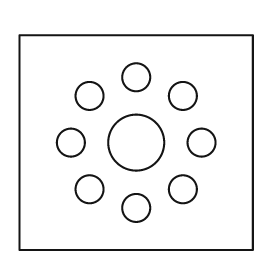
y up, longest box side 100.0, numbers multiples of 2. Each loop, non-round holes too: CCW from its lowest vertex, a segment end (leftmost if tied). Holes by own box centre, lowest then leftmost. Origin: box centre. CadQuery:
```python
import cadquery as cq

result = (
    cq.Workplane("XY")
    .moveTo(-50.0, -46.0)
    .lineTo(50.0, -46.0)
    .lineTo(50.0, 46.0)
    .lineTo(-50.0, 46.0)
    .close()
    .moveTo(0.0, -28.0)
    .circle(6.0)
    .moveTo(-20.0, -20.0)
    .circle(6.0)
    .moveTo(20.0, -20.0)
    .circle(6.0)
    .moveTo(-28.0, 0.0)
    .circle(6.0)
    .moveTo(0.0, 0.0)
    .circle(12.0)
    .moveTo(28.0, 0.0)
    .circle(6.0)
    .moveTo(-20.0, 20.0)
    .circle(6.0)
    .moveTo(20.0, 20.0)
    .circle(6.0)
    .moveTo(0.0, 28.0)
    .circle(6.0)
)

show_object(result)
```